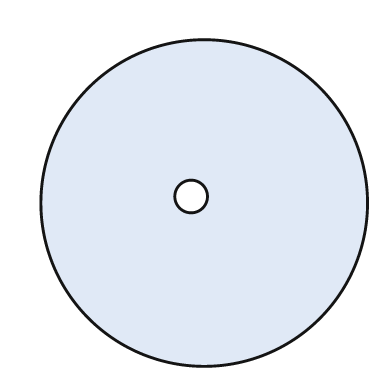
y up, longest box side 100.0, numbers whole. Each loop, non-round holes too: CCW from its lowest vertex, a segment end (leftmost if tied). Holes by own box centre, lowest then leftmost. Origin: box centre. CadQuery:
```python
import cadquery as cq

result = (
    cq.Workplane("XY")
    .moveTo(0.0, 0.0)
    .circle(50.0)
    .moveTo(-4.0, 2.0)
    .circle(5.0)
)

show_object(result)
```